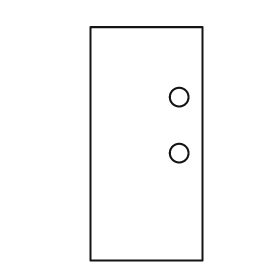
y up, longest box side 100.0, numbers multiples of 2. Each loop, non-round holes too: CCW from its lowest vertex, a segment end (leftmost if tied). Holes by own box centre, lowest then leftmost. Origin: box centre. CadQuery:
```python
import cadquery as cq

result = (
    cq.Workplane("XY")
    .moveTo(-24.0, -50.0)
    .lineTo(24.0, -50.0)
    .lineTo(24.0, 50.0)
    .lineTo(-24.0, 50.0)
    .close()
    .moveTo(14.0, -4.0)
    .circle(4.0)
    .moveTo(14.0, 20.0)
    .circle(4.0)
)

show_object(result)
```